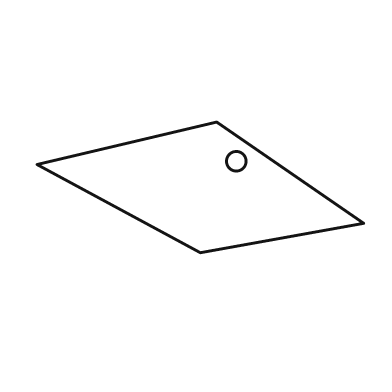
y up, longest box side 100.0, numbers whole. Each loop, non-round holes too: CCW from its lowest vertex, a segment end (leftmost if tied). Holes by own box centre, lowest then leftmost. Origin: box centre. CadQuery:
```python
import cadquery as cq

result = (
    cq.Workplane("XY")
    .moveTo(0.0, -20.0)
    .lineTo(50.0, -11.0)
    .lineTo(5.0, 20.0)
    .lineTo(-50.0, 7.0)
    .close()
    .moveTo(11.0, 8.0)
    .circle(3.0)
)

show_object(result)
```